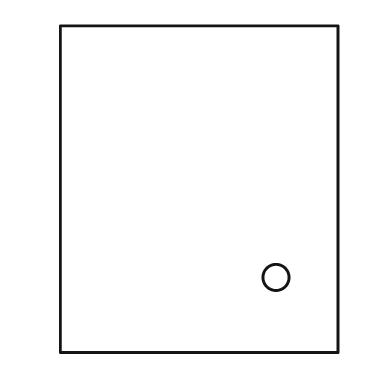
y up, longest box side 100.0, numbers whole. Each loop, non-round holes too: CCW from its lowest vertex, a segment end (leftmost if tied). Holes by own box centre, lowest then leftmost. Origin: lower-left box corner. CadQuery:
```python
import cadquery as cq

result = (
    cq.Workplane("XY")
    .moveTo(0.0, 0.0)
    .lineTo(85.0, 0.0)
    .lineTo(85.0, 100.0)
    .lineTo(0.0, 100.0)
    .close()
    .moveTo(66.0, 23.0)
    .circle(4.0)
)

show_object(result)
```